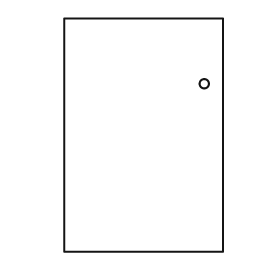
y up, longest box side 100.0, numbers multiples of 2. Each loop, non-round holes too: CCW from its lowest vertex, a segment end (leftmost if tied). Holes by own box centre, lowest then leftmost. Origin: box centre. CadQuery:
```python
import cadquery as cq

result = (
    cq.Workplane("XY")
    .moveTo(-34.0, -50.0)
    .lineTo(34.0, -50.0)
    .lineTo(34.0, 50.0)
    .lineTo(-34.0, 50.0)
    .close()
    .moveTo(26.0, 22.0)
    .circle(2.0)
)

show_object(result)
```